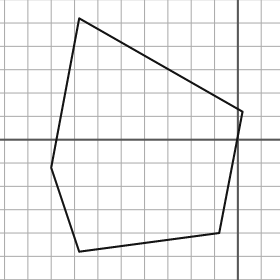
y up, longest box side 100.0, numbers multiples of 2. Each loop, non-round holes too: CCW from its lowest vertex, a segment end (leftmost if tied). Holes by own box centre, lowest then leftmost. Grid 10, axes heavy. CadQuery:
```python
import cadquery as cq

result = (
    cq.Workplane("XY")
    .moveTo(-68.0, -48.0)
    .lineTo(-8.0, -40.0)
    .lineTo(2.0, 12.0)
    .lineTo(-68.0, 52.0)
    .lineTo(-80.0, -12.0)
    .close()
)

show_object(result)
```